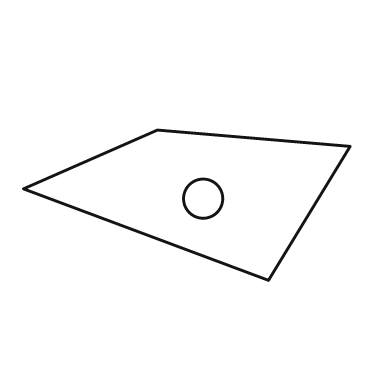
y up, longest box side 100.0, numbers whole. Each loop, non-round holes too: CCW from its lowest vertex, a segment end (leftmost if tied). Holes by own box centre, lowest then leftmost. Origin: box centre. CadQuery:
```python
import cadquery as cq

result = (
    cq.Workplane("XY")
    .moveTo(25.0, -23.0)
    .lineTo(50.0, 18.0)
    .lineTo(-9.0, 23.0)
    .lineTo(-50.0, 5.0)
    .close()
    .moveTo(5.0, 2.0)
    .circle(6.0)
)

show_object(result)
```